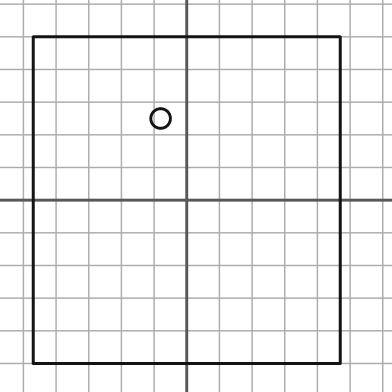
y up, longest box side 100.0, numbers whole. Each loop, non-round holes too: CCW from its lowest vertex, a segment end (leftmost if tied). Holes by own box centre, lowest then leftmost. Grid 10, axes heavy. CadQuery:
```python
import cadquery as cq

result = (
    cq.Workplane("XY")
    .moveTo(-47.0, -50.0)
    .lineTo(47.0, -50.0)
    .lineTo(47.0, 50.0)
    .lineTo(-47.0, 50.0)
    .close()
    .moveTo(-8.0, 25.0)
    .circle(3.0)
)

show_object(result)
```